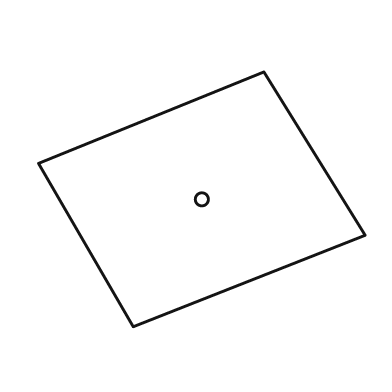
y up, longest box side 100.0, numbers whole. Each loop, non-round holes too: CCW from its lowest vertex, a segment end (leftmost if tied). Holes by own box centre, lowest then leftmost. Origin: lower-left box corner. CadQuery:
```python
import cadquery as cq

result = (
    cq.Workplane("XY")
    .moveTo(29.0, 0.0)
    .lineTo(100.0, 28.0)
    .lineTo(69.0, 78.0)
    .lineTo(0.0, 50.0)
    .close()
    .moveTo(50.0, 39.0)
    .circle(2.0)
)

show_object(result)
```